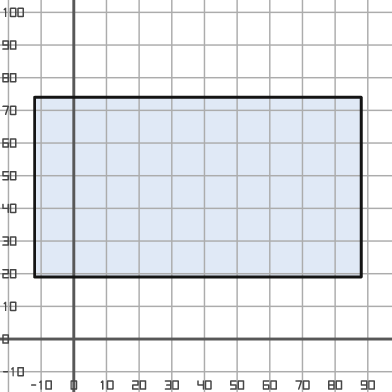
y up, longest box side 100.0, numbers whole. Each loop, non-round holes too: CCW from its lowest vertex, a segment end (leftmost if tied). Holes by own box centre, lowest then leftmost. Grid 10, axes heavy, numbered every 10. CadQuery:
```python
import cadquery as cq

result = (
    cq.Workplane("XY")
    .moveTo(-12.0, 19.0)
    .lineTo(88.0, 19.0)
    .lineTo(88.0, 74.0)
    .lineTo(-12.0, 74.0)
    .close()
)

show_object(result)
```